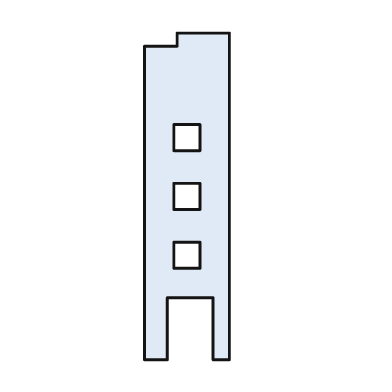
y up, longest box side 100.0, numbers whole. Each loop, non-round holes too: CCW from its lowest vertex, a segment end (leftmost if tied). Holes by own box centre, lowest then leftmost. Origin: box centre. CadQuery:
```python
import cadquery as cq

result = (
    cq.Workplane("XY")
    .moveTo(-13.0, -50.0)
    .lineTo(-6.0, -50.0)
    .lineTo(-6.0, -31.0)
    .lineTo(8.0, -31.0)
    .lineTo(8.0, -50.0)
    .lineTo(13.0, -50.0)
    .lineTo(13.0, 50.0)
    .lineTo(-3.0, 50.0)
    .lineTo(-3.0, 46.0)
    .lineTo(-13.0, 46.0)
    .close()
    .moveTo(-4.0, -22.0)
    .lineTo(4.0, -22.0)
    .lineTo(4.0, -14.0)
    .lineTo(-4.0, -14.0)
    .close()
    .moveTo(-4.0, -4.0)
    .lineTo(4.0, -4.0)
    .lineTo(4.0, 4.0)
    .lineTo(-4.0, 4.0)
    .close()
    .moveTo(-4.0, 14.0)
    .lineTo(4.0, 14.0)
    .lineTo(4.0, 22.0)
    .lineTo(-4.0, 22.0)
    .close()
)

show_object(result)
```